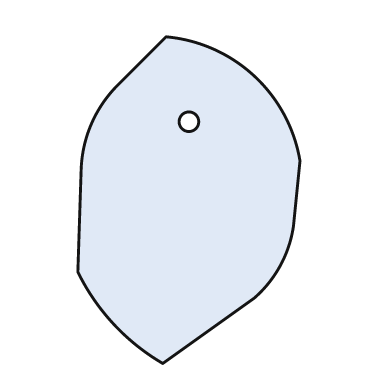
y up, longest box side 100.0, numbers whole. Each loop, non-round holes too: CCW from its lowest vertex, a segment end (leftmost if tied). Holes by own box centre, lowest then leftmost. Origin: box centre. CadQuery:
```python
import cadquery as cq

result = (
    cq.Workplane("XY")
    .moveTo(-8.0, -50.0)
    .lineTo(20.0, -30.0)
    .threePointArc((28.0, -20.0), (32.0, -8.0))
    .lineTo(34.0, 12.0)
    .threePointArc((20.0, 38.0), (-7.0, 50.0))
    .lineTo(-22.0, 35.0)
    .threePointArc((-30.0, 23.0), (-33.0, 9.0))
    .lineTo(-34.0, -22.0)
    .threePointArc((-23.0, -38.0), (-8.0, -50.0))
    .close()
    .moveTo(0.0, 24.0)
    .circle(3.0)
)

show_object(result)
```